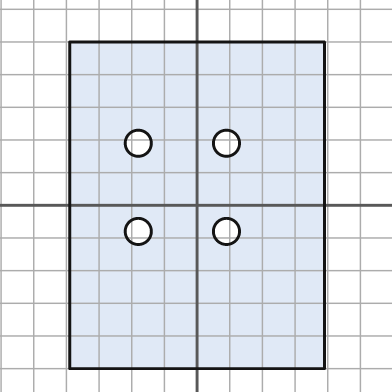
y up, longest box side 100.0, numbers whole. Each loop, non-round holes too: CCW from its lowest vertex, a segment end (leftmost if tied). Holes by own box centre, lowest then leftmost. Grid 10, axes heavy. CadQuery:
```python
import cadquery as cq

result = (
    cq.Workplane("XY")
    .moveTo(-39.0, -50.0)
    .lineTo(39.0, -50.0)
    .lineTo(39.0, 50.0)
    .lineTo(-39.0, 50.0)
    .close()
    .moveTo(-18.0, -8.0)
    .circle(4.0)
    .moveTo(9.0, -8.0)
    .circle(4.0)
    .moveTo(-18.0, 19.0)
    .circle(4.0)
    .moveTo(9.0, 19.0)
    .circle(4.0)
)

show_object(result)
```